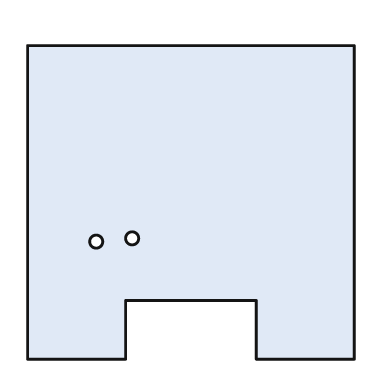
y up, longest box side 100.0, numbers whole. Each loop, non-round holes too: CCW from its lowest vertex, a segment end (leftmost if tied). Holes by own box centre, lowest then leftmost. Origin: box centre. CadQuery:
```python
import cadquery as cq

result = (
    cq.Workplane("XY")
    .moveTo(-50.0, -48.0)
    .lineTo(-20.0, -48.0)
    .lineTo(-20.0, -30.0)
    .lineTo(20.0, -30.0)
    .lineTo(20.0, -48.0)
    .lineTo(50.0, -48.0)
    .lineTo(50.0, 48.0)
    .lineTo(-50.0, 48.0)
    .close()
    .moveTo(-29.0, -12.0)
    .circle(2.0)
    .moveTo(-18.0, -11.0)
    .circle(2.0)
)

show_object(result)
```